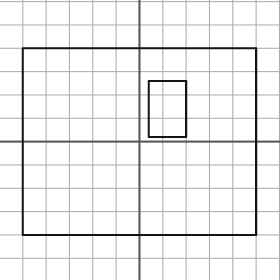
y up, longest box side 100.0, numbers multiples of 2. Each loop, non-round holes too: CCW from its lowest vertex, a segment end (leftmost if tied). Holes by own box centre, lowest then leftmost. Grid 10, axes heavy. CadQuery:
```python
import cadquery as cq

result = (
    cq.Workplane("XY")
    .moveTo(-50.0, -40.0)
    .lineTo(50.0, -40.0)
    .lineTo(50.0, 40.0)
    .lineTo(-50.0, 40.0)
    .close()
    .moveTo(4.0, 2.0)
    .lineTo(20.0, 2.0)
    .lineTo(20.0, 26.0)
    .lineTo(4.0, 26.0)
    .close()
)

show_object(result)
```